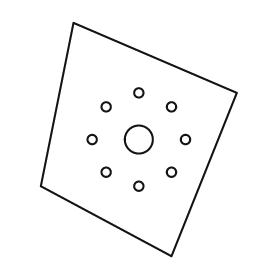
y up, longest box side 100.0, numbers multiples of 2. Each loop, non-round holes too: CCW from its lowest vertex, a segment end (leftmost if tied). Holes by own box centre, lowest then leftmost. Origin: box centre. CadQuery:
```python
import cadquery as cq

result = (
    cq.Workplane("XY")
    .moveTo(14.0, -50.0)
    .lineTo(42.0, 20.0)
    .lineTo(-28.0, 50.0)
    .lineTo(-42.0, -20.0)
    .close()
    .moveTo(0.0, -20.0)
    .circle(2.0)
    .moveTo(-14.0, -14.0)
    .circle(2.0)
    .moveTo(14.0, -14.0)
    .circle(2.0)
    .moveTo(-20.0, 0.0)
    .circle(2.0)
    .moveTo(0.0, 0.0)
    .circle(6.0)
    .moveTo(20.0, 0.0)
    .circle(2.0)
    .moveTo(-14.0, 14.0)
    .circle(2.0)
    .moveTo(14.0, 14.0)
    .circle(2.0)
    .moveTo(0.0, 20.0)
    .circle(2.0)
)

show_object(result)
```